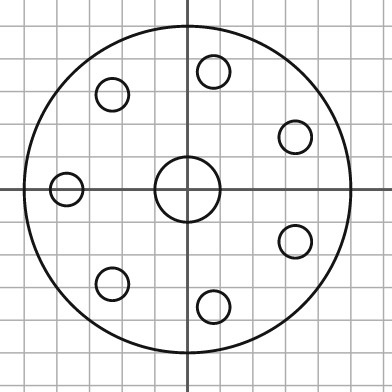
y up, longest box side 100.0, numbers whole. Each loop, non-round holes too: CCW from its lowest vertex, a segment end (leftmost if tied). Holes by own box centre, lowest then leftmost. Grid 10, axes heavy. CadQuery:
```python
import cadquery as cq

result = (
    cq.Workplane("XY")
    .moveTo(0.0, 0.0)
    .circle(50.0)
    .moveTo(8.0, -36.0)
    .circle(5.0)
    .moveTo(-23.0, -29.0)
    .circle(5.0)
    .moveTo(33.0, -16.0)
    .circle(5.0)
    .moveTo(-37.0, 0.0)
    .circle(5.0)
    .moveTo(0.0, 0.0)
    .circle(10.0)
    .moveTo(33.0, 16.0)
    .circle(5.0)
    .moveTo(-23.0, 29.0)
    .circle(5.0)
    .moveTo(8.0, 36.0)
    .circle(5.0)
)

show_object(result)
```